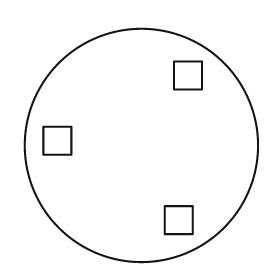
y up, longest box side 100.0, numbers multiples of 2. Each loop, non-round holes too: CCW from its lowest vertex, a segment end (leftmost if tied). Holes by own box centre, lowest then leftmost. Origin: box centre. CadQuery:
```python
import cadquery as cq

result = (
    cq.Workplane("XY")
    .moveTo(0.0, 0.0)
    .circle(50.0)
    .moveTo(10.0, -38.0)
    .lineTo(22.0, -38.0)
    .lineTo(22.0, -26.0)
    .lineTo(10.0, -26.0)
    .close()
    .moveTo(-42.0, -4.0)
    .lineTo(-30.0, -4.0)
    .lineTo(-30.0, 8.0)
    .lineTo(-42.0, 8.0)
    .close()
    .moveTo(14.0, 24.0)
    .lineTo(26.0, 24.0)
    .lineTo(26.0, 36.0)
    .lineTo(14.0, 36.0)
    .close()
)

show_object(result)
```